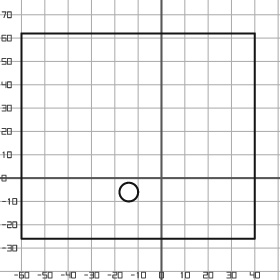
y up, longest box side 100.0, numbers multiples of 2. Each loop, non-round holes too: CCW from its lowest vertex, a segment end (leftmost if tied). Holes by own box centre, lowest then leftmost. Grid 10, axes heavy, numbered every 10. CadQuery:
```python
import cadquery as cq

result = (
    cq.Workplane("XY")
    .moveTo(-60.0, -26.0)
    .lineTo(40.0, -26.0)
    .lineTo(40.0, 62.0)
    .lineTo(-60.0, 62.0)
    .close()
    .moveTo(-14.0, -6.0)
    .circle(4.0)
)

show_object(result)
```